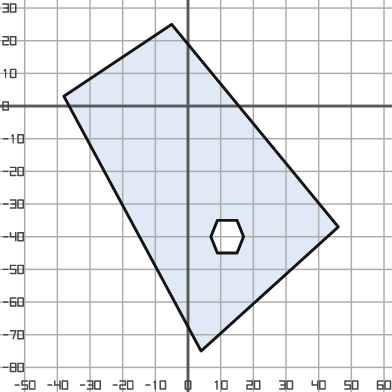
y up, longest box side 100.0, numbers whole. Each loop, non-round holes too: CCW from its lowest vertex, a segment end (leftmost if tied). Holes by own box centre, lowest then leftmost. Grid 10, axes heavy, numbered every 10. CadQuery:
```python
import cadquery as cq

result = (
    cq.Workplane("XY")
    .moveTo(4.0, -75.0)
    .lineTo(46.0, -37.0)
    .lineTo(-5.0, 25.0)
    .lineTo(-38.0, 3.0)
    .close()
    .moveTo(9.0, -45.0)
    .lineTo(15.0, -45.0)
    .lineTo(17.0, -40.0)
    .lineTo(15.0, -35.0)
    .lineTo(9.0, -35.0)
    .lineTo(7.0, -40.0)
    .close()
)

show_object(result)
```